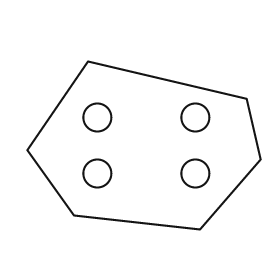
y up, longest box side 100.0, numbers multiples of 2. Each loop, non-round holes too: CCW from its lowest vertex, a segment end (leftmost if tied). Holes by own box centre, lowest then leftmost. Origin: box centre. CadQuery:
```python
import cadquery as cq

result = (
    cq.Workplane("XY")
    .moveTo(24.0, -36.0)
    .lineTo(50.0, -6.0)
    .lineTo(44.0, 20.0)
    .lineTo(-24.0, 36.0)
    .lineTo(-50.0, -2.0)
    .lineTo(-30.0, -30.0)
    .close()
    .moveTo(-20.0, -12.0)
    .circle(6.0)
    .moveTo(22.0, -12.0)
    .circle(6.0)
    .moveTo(-20.0, 12.0)
    .circle(6.0)
    .moveTo(22.0, 12.0)
    .circle(6.0)
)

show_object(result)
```